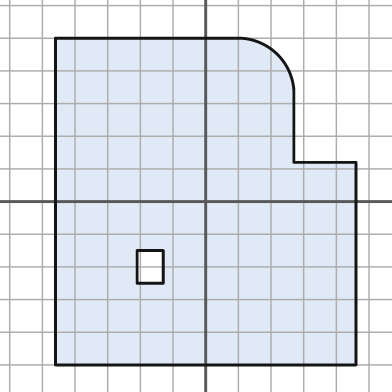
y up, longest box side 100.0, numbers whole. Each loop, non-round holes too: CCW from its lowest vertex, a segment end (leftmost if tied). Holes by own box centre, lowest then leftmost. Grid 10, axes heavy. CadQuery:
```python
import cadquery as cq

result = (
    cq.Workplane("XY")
    .moveTo(-46.0, -50.0)
    .lineTo(46.0, -50.0)
    .lineTo(46.0, 12.0)
    .lineTo(27.0, 12.0)
    .lineTo(27.0, 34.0)
    .threePointArc((22.0, 45.0), (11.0, 50.0))
    .lineTo(-46.0, 50.0)
    .close()
    .moveTo(-21.0, -25.0)
    .lineTo(-13.0, -25.0)
    .lineTo(-13.0, -15.0)
    .lineTo(-21.0, -15.0)
    .close()
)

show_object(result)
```